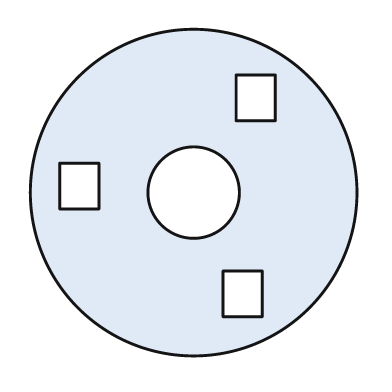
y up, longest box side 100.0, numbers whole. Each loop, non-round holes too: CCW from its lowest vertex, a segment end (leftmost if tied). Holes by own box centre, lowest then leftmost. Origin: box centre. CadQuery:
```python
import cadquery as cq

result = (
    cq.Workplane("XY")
    .moveTo(0.0, 0.0)
    .circle(50.0)
    .moveTo(9.0, -38.0)
    .lineTo(21.0, -38.0)
    .lineTo(21.0, -24.0)
    .lineTo(9.0, -24.0)
    .close()
    .moveTo(0.0, 0.0)
    .circle(14.0)
    .moveTo(-41.0, -5.0)
    .lineTo(-29.0, -5.0)
    .lineTo(-29.0, 9.0)
    .lineTo(-41.0, 9.0)
    .close()
    .moveTo(13.0, 22.0)
    .lineTo(25.0, 22.0)
    .lineTo(25.0, 36.0)
    .lineTo(13.0, 36.0)
    .close()
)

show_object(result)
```